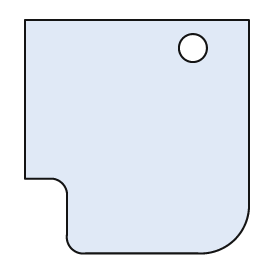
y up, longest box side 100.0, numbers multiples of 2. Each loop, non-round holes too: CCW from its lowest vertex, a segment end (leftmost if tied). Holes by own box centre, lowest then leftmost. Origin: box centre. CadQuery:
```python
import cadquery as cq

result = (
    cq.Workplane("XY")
    .moveTo(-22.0, -50.0)
    .lineTo(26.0, -50.0)
    .threePointArc((42.0, -44.0), (48.0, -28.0))
    .lineTo(48.0, 50.0)
    .lineTo(-48.0, 50.0)
    .lineTo(-48.0, -18.0)
    .lineTo(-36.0, -18.0)
    .threePointArc((-32.0, -20.0), (-30.0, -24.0))
    .lineTo(-30.0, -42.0)
    .threePointArc((-28.0, -48.0), (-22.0, -50.0))
    .close()
    .moveTo(24.0, 38.0)
    .circle(6.0)
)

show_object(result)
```